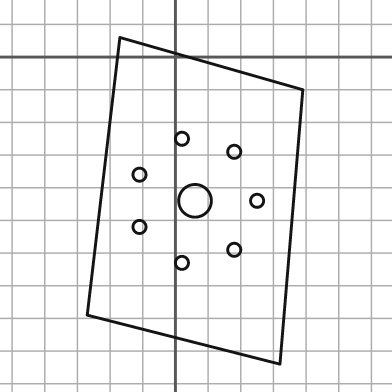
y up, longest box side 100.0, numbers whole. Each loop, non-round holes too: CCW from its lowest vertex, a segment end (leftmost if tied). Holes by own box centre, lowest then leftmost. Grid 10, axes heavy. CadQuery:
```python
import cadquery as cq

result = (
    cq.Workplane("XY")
    .moveTo(32.0, -94.0)
    .lineTo(39.0, -10.0)
    .lineTo(-17.0, 6.0)
    .lineTo(-27.0, -79.0)
    .close()
    .moveTo(2.0, -63.0)
    .circle(2.0)
    .moveTo(18.0, -59.0)
    .circle(2.0)
    .moveTo(-11.0, -52.0)
    .circle(2.0)
    .moveTo(6.0, -44.0)
    .circle(5.0)
    .moveTo(25.0, -44.0)
    .circle(2.0)
    .moveTo(-11.0, -36.0)
    .circle(2.0)
    .moveTo(18.0, -29.0)
    .circle(2.0)
    .moveTo(2.0, -25.0)
    .circle(2.0)
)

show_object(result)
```